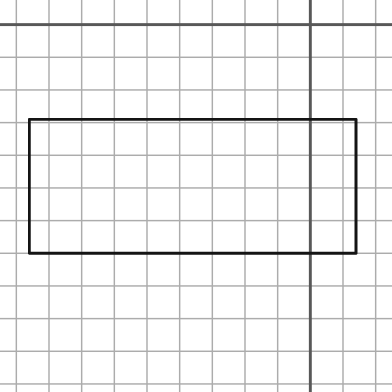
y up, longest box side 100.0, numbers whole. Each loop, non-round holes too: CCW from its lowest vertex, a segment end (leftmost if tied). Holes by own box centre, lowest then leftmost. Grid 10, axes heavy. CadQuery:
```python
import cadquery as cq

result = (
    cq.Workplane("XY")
    .moveTo(-86.0, -70.0)
    .lineTo(14.0, -70.0)
    .lineTo(14.0, -29.0)
    .lineTo(-86.0, -29.0)
    .close()
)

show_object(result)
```